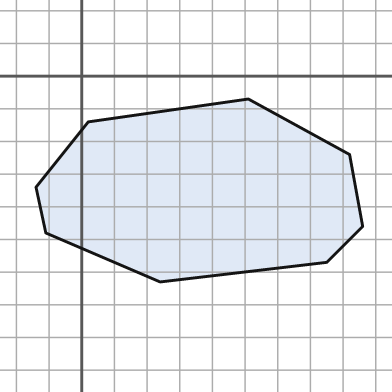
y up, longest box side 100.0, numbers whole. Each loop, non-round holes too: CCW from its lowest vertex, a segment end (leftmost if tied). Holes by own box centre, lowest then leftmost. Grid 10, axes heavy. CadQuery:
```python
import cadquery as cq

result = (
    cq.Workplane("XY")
    .moveTo(24.0, -63.0)
    .lineTo(75.0, -57.0)
    .lineTo(86.0, -46.0)
    .lineTo(82.0, -24.0)
    .lineTo(51.0, -7.0)
    .lineTo(2.0, -14.0)
    .lineTo(-14.0, -34.0)
    .lineTo(-11.0, -48.0)
    .close()
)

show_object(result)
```